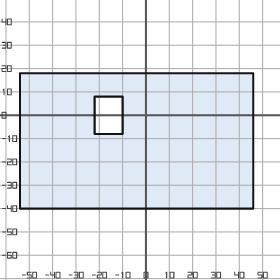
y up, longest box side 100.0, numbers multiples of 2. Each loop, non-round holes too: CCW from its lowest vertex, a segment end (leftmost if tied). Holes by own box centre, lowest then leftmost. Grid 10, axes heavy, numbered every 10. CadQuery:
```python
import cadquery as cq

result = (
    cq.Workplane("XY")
    .moveTo(-54.0, -40.0)
    .lineTo(46.0, -40.0)
    .lineTo(46.0, 18.0)
    .lineTo(-54.0, 18.0)
    .close()
    .moveTo(-22.0, -8.0)
    .lineTo(-10.0, -8.0)
    .lineTo(-10.0, 8.0)
    .lineTo(-22.0, 8.0)
    .close()
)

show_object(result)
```